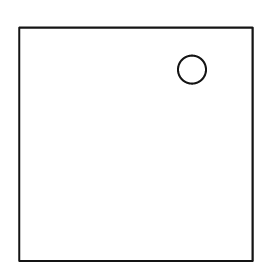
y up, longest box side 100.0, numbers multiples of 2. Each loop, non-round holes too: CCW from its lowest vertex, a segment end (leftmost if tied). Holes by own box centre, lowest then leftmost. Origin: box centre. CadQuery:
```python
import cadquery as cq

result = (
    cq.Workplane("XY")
    .moveTo(-50.0, -50.0)
    .lineTo(50.0, -50.0)
    .lineTo(50.0, 50.0)
    .lineTo(-50.0, 50.0)
    .close()
    .moveTo(24.0, 32.0)
    .circle(6.0)
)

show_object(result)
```